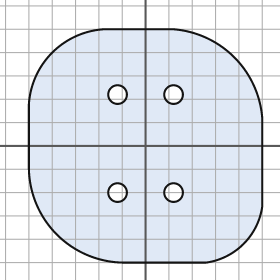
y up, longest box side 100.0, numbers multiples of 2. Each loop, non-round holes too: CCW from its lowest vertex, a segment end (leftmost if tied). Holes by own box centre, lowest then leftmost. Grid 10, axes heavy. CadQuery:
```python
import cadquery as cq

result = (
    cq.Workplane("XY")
    .moveTo(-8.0, -50.0)
    .lineTo(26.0, -50.0)
    .threePointArc((42.0, -42.0), (50.0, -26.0))
    .lineTo(50.0, 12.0)
    .threePointArc((38.0, 38.0), (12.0, 50.0))
    .lineTo(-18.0, 50.0)
    .threePointArc((-40.0, 40.0), (-50.0, 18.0))
    .lineTo(-50.0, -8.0)
    .threePointArc((-38.0, -38.0), (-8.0, -50.0))
    .close()
    .moveTo(-12.0, -20.0)
    .circle(4.0)
    .moveTo(12.0, -20.0)
    .circle(4.0)
    .moveTo(-12.0, 22.0)
    .circle(4.0)
    .moveTo(12.0, 22.0)
    .circle(4.0)
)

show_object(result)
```